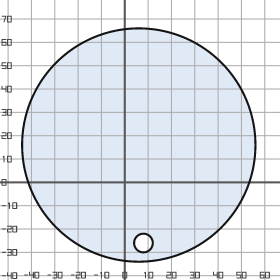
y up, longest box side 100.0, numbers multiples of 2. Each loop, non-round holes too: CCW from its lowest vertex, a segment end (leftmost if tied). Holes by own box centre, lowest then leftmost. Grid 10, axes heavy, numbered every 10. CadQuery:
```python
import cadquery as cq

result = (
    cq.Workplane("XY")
    .moveTo(6.0, 16.0)
    .circle(50.0)
    .moveTo(8.0, -26.0)
    .circle(4.0)
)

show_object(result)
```